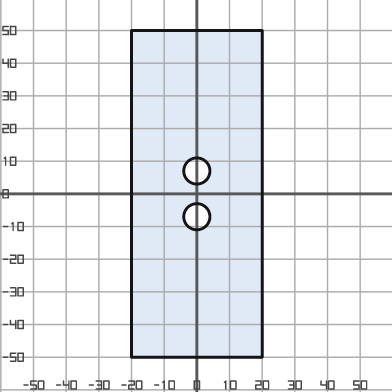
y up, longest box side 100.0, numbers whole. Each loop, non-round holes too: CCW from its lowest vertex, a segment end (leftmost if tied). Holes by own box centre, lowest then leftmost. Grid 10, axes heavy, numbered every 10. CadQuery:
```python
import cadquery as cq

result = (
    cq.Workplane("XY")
    .moveTo(-20.0, -50.0)
    .lineTo(20.0, -50.0)
    .lineTo(20.0, 50.0)
    .lineTo(-20.0, 50.0)
    .close()
    .moveTo(0.0, -7.0)
    .circle(4.0)
    .moveTo(0.0, 7.0)
    .circle(4.0)
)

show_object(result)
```